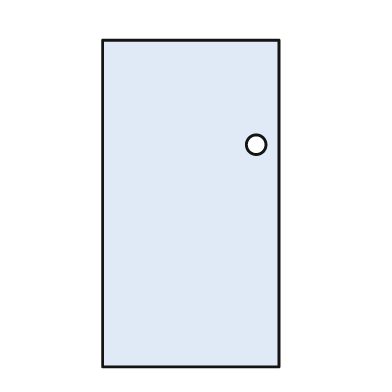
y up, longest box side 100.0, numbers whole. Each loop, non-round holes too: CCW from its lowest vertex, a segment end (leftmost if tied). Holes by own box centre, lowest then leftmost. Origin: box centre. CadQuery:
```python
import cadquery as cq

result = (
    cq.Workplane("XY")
    .moveTo(-27.0, -50.0)
    .lineTo(27.0, -50.0)
    .lineTo(27.0, 50.0)
    .lineTo(-27.0, 50.0)
    .close()
    .moveTo(20.0, 18.0)
    .circle(3.0)
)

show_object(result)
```